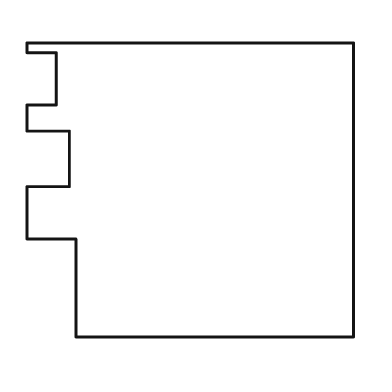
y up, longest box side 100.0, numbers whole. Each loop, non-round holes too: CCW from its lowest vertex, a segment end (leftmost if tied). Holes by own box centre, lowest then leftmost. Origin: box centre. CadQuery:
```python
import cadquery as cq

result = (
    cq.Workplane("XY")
    .moveTo(-35.0, -45.0)
    .lineTo(50.0, -45.0)
    .lineTo(50.0, 45.0)
    .lineTo(-50.0, 45.0)
    .lineTo(-50.0, 42.0)
    .lineTo(-41.0, 42.0)
    .lineTo(-41.0, 26.0)
    .lineTo(-50.0, 26.0)
    .lineTo(-50.0, 18.0)
    .lineTo(-37.0, 18.0)
    .lineTo(-37.0, 1.0)
    .lineTo(-50.0, 1.0)
    .lineTo(-50.0, -15.0)
    .lineTo(-35.0, -15.0)
    .close()
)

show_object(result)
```